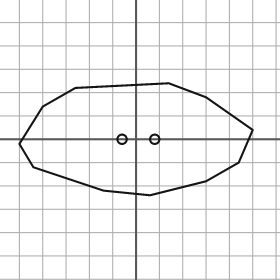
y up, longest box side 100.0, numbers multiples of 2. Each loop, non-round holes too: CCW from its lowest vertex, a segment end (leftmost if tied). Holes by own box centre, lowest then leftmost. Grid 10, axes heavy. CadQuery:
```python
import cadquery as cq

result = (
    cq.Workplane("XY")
    .moveTo(6.0, -24.0)
    .lineTo(30.0, -18.0)
    .lineTo(44.0, -10.0)
    .lineTo(50.0, 4.0)
    .lineTo(30.0, 18.0)
    .lineTo(14.0, 24.0)
    .lineTo(-26.0, 22.0)
    .lineTo(-40.0, 14.0)
    .lineTo(-50.0, -2.0)
    .lineTo(-44.0, -12.0)
    .lineTo(-14.0, -22.0)
    .close()
    .moveTo(-6.0, 0.0)
    .circle(2.0)
    .moveTo(8.0, 0.0)
    .circle(2.0)
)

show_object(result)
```